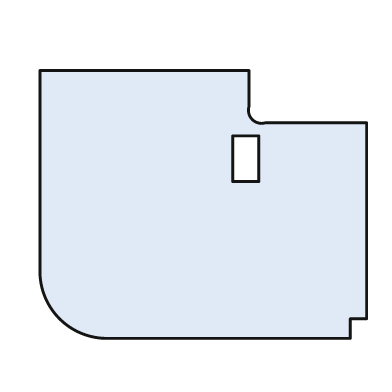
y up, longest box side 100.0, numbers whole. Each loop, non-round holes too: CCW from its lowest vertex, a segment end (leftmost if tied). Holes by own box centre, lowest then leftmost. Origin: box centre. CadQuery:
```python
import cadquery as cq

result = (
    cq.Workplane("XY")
    .moveTo(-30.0, -41.0)
    .lineTo(45.0, -41.0)
    .lineTo(45.0, -35.0)
    .lineTo(50.0, -35.0)
    .lineTo(50.0, 25.0)
    .lineTo(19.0, 25.0)
    .threePointArc((15.0, 26.0), (14.0, 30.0))
    .lineTo(14.0, 41.0)
    .lineTo(-50.0, 41.0)
    .lineTo(-50.0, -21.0)
    .threePointArc((-44.0, -35.0), (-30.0, -41.0))
    .close()
    .moveTo(9.0, 7.0)
    .lineTo(17.0, 7.0)
    .lineTo(17.0, 21.0)
    .lineTo(9.0, 21.0)
    .close()
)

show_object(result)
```